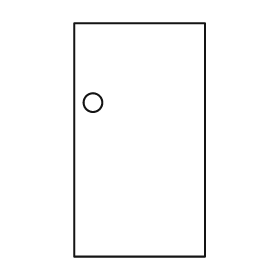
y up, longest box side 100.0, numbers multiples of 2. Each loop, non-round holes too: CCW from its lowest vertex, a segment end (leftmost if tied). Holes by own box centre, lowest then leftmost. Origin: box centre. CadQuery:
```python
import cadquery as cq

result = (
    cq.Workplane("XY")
    .moveTo(-28.0, -50.0)
    .lineTo(28.0, -50.0)
    .lineTo(28.0, 50.0)
    .lineTo(-28.0, 50.0)
    .close()
    .moveTo(-20.0, 16.0)
    .circle(4.0)
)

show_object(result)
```